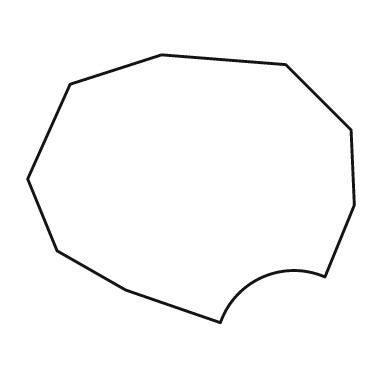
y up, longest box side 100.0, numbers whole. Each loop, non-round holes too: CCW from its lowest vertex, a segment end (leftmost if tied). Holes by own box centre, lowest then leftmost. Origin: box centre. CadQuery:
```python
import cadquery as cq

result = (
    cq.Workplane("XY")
    .moveTo(9.0, -41.0)
    .threePointArc((22.0, -27.0), (41.0, -27.0))
    .lineTo(50.0, -5.0)
    .lineTo(49.0, 18.0)
    .lineTo(29.0, 38.0)
    .lineTo(-9.0, 41.0)
    .lineTo(-37.0, 32.0)
    .lineTo(-50.0, 3.0)
    .lineTo(-41.0, -19.0)
    .lineTo(-20.0, -31.0)
    .close()
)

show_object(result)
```